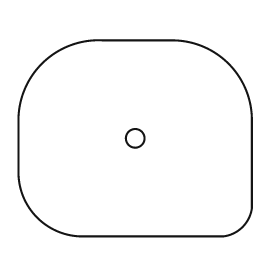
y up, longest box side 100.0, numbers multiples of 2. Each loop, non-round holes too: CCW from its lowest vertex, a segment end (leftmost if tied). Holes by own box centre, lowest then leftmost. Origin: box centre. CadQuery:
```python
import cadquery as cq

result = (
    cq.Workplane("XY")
    .moveTo(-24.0, -42.0)
    .lineTo(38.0, -42.0)
    .threePointArc((46.0, -38.0), (50.0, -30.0))
    .lineTo(50.0, 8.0)
    .threePointArc((40.0, 32.0), (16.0, 42.0))
    .lineTo(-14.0, 42.0)
    .threePointArc((-40.0, 32.0), (-50.0, 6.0))
    .lineTo(-50.0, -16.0)
    .threePointArc((-42.0, -34.0), (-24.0, -42.0))
    .close()
    .moveTo(0.0, 0.0)
    .circle(4.0)
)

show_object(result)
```